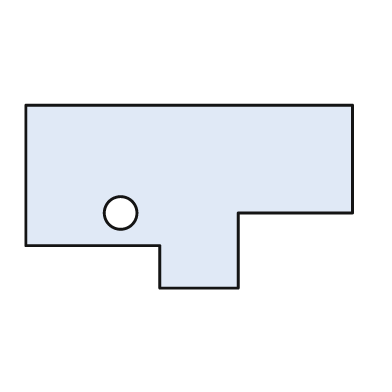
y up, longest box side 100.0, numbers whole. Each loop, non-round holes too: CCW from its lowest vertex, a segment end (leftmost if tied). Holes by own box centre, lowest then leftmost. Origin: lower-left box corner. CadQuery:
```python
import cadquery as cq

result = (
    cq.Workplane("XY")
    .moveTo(41.0, 0.0)
    .lineTo(65.0, 0.0)
    .lineTo(65.0, 23.0)
    .lineTo(100.0, 23.0)
    .lineTo(100.0, 56.0)
    .lineTo(0.0, 56.0)
    .lineTo(0.0, 13.0)
    .lineTo(41.0, 13.0)
    .close()
    .moveTo(29.0, 23.0)
    .circle(5.0)
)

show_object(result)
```